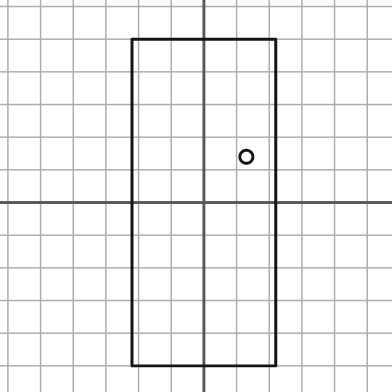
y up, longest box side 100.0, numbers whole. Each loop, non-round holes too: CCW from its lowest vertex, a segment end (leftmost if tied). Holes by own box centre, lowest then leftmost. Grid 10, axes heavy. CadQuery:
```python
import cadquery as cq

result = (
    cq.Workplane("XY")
    .moveTo(-22.0, -50.0)
    .lineTo(22.0, -50.0)
    .lineTo(22.0, 50.0)
    .lineTo(-22.0, 50.0)
    .close()
    .moveTo(13.0, 14.0)
    .circle(2.0)
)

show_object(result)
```